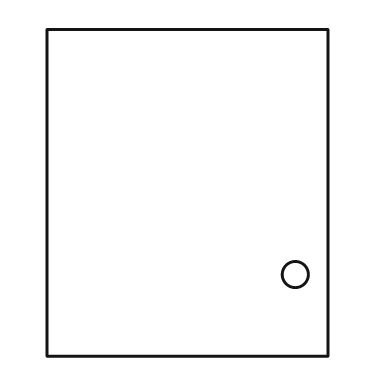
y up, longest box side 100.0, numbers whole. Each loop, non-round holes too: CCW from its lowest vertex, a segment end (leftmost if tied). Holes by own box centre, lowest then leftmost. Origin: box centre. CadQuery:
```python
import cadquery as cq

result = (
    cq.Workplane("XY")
    .moveTo(-43.0, -50.0)
    .lineTo(43.0, -50.0)
    .lineTo(43.0, 50.0)
    .lineTo(-43.0, 50.0)
    .close()
    .moveTo(33.0, -25.0)
    .circle(4.0)
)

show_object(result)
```